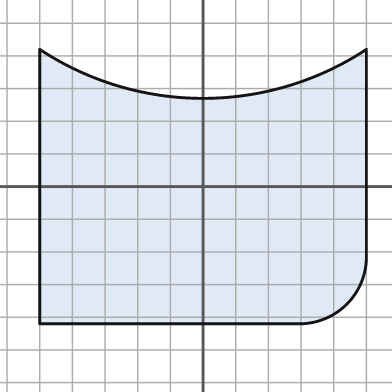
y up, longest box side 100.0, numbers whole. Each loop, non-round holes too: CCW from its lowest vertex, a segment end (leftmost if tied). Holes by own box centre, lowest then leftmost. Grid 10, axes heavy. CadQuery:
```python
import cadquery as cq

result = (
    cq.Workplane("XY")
    .moveTo(-50.0, -42.0)
    .lineTo(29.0, -42.0)
    .threePointArc((44.0, -36.0), (50.0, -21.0))
    .lineTo(50.0, 42.0)
    .threePointArc((0.0, 27.0), (-50.0, 42.0))
    .close()
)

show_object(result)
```